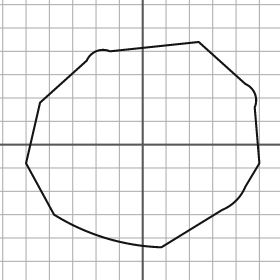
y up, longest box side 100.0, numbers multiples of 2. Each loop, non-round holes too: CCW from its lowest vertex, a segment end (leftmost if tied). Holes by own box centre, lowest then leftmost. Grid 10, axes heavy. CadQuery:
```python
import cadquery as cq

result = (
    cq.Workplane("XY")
    .moveTo(8.0, -44.0)
    .lineTo(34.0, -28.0)
    .threePointArc((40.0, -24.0), (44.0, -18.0))
    .lineTo(50.0, -8.0)
    .lineTo(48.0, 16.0)
    .threePointArc((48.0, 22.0), (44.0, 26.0))
    .lineTo(24.0, 44.0)
    .lineTo(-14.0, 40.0)
    .threePointArc((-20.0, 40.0), (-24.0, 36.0))
    .lineTo(-44.0, 18.0)
    .lineTo(-50.0, -8.0)
    .lineTo(-38.0, -30.0)
    .threePointArc((-16.0, -40.0), (8.0, -44.0))
    .close()
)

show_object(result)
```